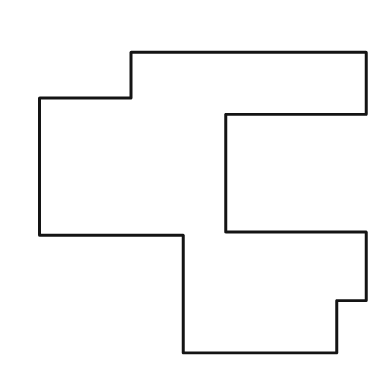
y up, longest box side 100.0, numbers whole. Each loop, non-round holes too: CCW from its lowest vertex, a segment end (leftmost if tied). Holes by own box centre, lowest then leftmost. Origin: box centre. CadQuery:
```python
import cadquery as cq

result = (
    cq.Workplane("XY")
    .moveTo(-6.0, -46.0)
    .lineTo(41.0, -46.0)
    .lineTo(41.0, -30.0)
    .lineTo(50.0, -30.0)
    .lineTo(50.0, -9.0)
    .lineTo(7.0, -9.0)
    .lineTo(7.0, 27.0)
    .lineTo(50.0, 27.0)
    .lineTo(50.0, 46.0)
    .lineTo(-22.0, 46.0)
    .lineTo(-22.0, 32.0)
    .lineTo(-50.0, 32.0)
    .lineTo(-50.0, -10.0)
    .lineTo(-6.0, -10.0)
    .close()
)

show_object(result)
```